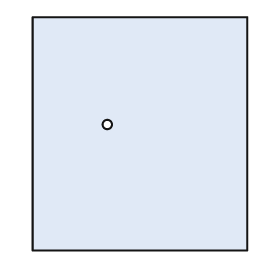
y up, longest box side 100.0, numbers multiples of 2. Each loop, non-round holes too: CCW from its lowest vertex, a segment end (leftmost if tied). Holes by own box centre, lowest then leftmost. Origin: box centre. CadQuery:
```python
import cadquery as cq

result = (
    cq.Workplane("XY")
    .moveTo(-46.0, -50.0)
    .lineTo(46.0, -50.0)
    .lineTo(46.0, 50.0)
    .lineTo(-46.0, 50.0)
    .close()
    .moveTo(-14.0, 4.0)
    .circle(2.0)
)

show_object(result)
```